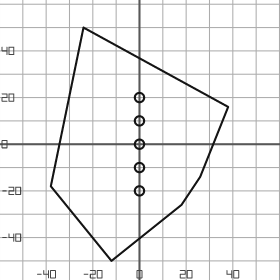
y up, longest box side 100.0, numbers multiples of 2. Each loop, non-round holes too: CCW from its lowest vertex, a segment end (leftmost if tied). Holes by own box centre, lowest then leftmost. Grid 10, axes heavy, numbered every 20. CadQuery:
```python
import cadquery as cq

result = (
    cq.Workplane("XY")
    .moveTo(-12.0, -50.0)
    .lineTo(18.0, -26.0)
    .lineTo(26.0, -14.0)
    .lineTo(38.0, 16.0)
    .lineTo(-24.0, 50.0)
    .lineTo(-38.0, -18.0)
    .close()
    .moveTo(0.0, -20.0)
    .circle(2.0)
    .moveTo(0.0, -10.0)
    .circle(2.0)
    .moveTo(0.0, 0.0)
    .circle(2.0)
    .moveTo(0.0, 10.0)
    .circle(2.0)
    .moveTo(0.0, 20.0)
    .circle(2.0)
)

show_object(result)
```